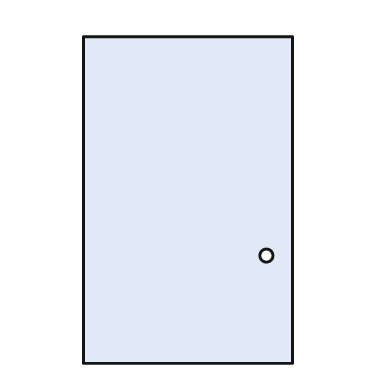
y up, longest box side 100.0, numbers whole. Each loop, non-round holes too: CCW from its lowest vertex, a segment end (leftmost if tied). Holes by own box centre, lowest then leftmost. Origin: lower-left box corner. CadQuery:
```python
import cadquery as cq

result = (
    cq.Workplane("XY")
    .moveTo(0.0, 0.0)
    .lineTo(64.0, 0.0)
    .lineTo(64.0, 100.0)
    .lineTo(0.0, 100.0)
    .close()
    .moveTo(56.0, 33.0)
    .circle(2.0)
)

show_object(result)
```